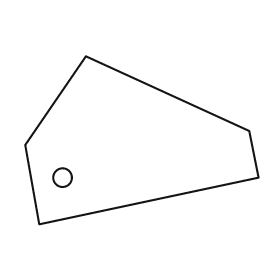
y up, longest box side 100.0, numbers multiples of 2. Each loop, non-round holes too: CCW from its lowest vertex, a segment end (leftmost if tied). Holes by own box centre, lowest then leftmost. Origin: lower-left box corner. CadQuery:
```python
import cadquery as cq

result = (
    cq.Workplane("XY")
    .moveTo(6.0, 0.0)
    .lineTo(100.0, 20.0)
    .lineTo(96.0, 40.0)
    .lineTo(26.0, 72.0)
    .lineTo(0.0, 34.0)
    .close()
    .moveTo(16.0, 20.0)
    .circle(4.0)
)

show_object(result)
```